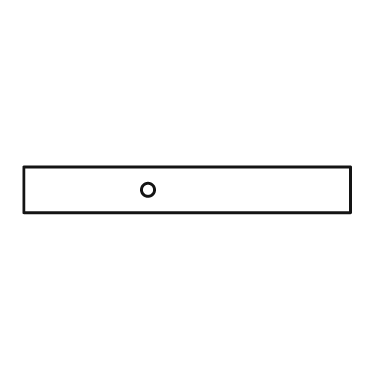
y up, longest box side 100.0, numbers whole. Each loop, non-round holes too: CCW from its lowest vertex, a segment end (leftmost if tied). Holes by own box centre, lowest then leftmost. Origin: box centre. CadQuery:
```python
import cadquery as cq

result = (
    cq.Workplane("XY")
    .moveTo(-50.0, -7.0)
    .lineTo(50.0, -7.0)
    .lineTo(50.0, 7.0)
    .lineTo(-50.0, 7.0)
    .close()
    .moveTo(-12.0, 0.0)
    .circle(2.0)
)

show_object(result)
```